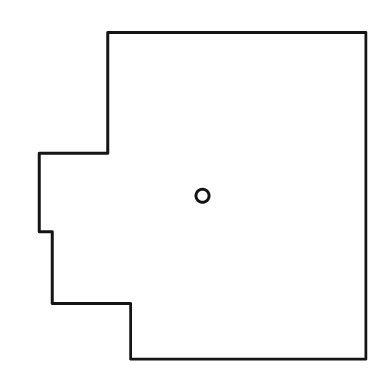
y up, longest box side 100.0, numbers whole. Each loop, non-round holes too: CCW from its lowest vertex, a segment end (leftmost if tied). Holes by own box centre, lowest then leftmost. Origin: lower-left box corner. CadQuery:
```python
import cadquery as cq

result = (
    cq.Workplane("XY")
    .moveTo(28.0, 0.0)
    .lineTo(100.0, 0.0)
    .lineTo(100.0, 100.0)
    .lineTo(21.0, 100.0)
    .lineTo(21.0, 63.0)
    .lineTo(0.0, 63.0)
    .lineTo(0.0, 39.0)
    .lineTo(4.0, 39.0)
    .lineTo(4.0, 17.0)
    .lineTo(28.0, 17.0)
    .close()
    .moveTo(50.0, 50.0)
    .circle(2.0)
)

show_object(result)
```